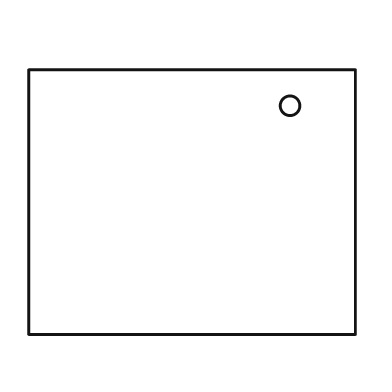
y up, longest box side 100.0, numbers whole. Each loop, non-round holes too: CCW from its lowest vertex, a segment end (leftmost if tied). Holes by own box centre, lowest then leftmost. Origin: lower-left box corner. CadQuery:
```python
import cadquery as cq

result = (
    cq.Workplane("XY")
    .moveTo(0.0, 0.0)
    .lineTo(100.0, 0.0)
    .lineTo(100.0, 81.0)
    .lineTo(0.0, 81.0)
    .close()
    .moveTo(80.0, 70.0)
    .circle(3.0)
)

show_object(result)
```